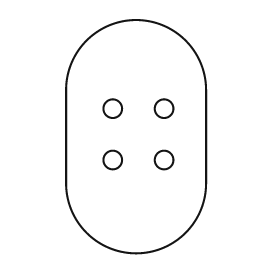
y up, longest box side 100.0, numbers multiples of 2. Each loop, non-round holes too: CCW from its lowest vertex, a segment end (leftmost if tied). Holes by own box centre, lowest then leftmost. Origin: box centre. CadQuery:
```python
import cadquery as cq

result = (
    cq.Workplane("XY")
    .moveTo(-30.0, -20.0)
    .threePointArc((0.0, -50.0), (30.0, -20.0))
    .lineTo(30.0, 20.0)
    .threePointArc((0.0, 50.0), (-30.0, 20.0))
    .close()
    .moveTo(-10.0, -10.0)
    .circle(4.0)
    .moveTo(12.0, -10.0)
    .circle(4.0)
    .moveTo(-10.0, 12.0)
    .circle(4.0)
    .moveTo(12.0, 12.0)
    .circle(4.0)
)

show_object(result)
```